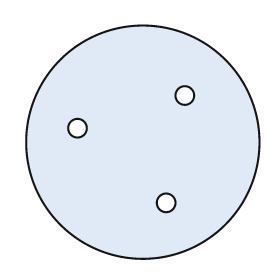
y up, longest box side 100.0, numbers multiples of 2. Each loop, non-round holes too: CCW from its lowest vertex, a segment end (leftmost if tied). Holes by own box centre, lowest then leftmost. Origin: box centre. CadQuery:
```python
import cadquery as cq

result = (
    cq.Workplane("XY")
    .moveTo(0.0, 0.0)
    .circle(50.0)
    .moveTo(10.0, -26.0)
    .circle(4.0)
    .moveTo(-28.0, 6.0)
    .circle(4.0)
    .moveTo(18.0, 20.0)
    .circle(4.0)
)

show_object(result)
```